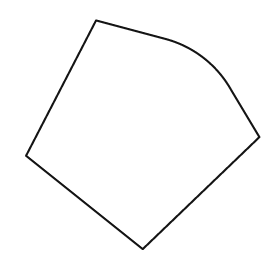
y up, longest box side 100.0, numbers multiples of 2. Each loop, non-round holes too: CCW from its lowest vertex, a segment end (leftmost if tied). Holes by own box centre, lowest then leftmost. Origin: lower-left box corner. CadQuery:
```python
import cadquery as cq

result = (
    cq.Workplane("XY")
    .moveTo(50.0, 0.0)
    .lineTo(100.0, 48.0)
    .lineTo(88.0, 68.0)
    .threePointArc((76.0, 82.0), (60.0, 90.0))
    .lineTo(30.0, 98.0)
    .lineTo(0.0, 40.0)
    .close()
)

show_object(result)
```